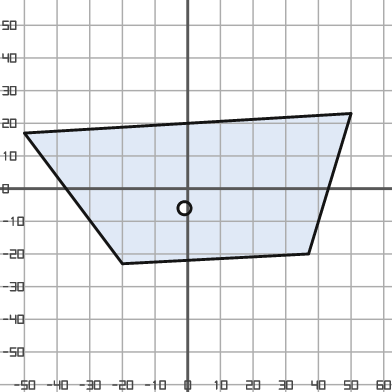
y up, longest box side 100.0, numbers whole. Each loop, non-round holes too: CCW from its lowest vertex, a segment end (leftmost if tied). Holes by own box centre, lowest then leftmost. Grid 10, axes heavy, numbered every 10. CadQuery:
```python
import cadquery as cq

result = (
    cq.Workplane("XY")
    .moveTo(-20.0, -23.0)
    .lineTo(37.0, -20.0)
    .lineTo(50.0, 23.0)
    .lineTo(-50.0, 17.0)
    .close()
    .moveTo(-1.0, -6.0)
    .circle(2.0)
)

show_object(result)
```